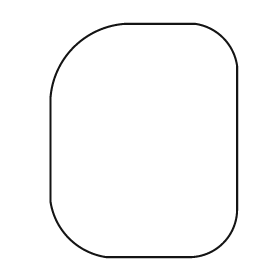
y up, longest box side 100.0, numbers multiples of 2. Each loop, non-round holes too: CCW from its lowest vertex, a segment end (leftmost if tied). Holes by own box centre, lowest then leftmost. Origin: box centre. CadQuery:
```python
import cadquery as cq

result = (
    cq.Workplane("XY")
    .moveTo(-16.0, -50.0)
    .lineTo(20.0, -50.0)
    .threePointArc((34.0, -44.0), (40.0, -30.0))
    .lineTo(40.0, 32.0)
    .threePointArc((34.0, 44.0), (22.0, 50.0))
    .lineTo(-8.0, 50.0)
    .threePointArc((-30.0, 40.0), (-40.0, 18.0))
    .lineTo(-40.0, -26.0)
    .threePointArc((-32.0, -42.0), (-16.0, -50.0))
    .close()
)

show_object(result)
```